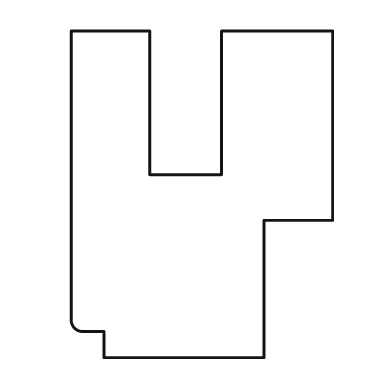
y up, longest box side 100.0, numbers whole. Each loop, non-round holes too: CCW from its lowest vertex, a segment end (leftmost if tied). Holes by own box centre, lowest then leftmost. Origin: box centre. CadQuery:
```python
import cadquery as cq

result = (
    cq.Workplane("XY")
    .moveTo(-30.0, -50.0)
    .lineTo(19.0, -50.0)
    .lineTo(19.0, -8.0)
    .lineTo(40.0, -8.0)
    .lineTo(40.0, 50.0)
    .lineTo(6.0, 50.0)
    .lineTo(6.0, 6.0)
    .lineTo(-16.0, 6.0)
    .lineTo(-16.0, 50.0)
    .lineTo(-40.0, 50.0)
    .lineTo(-40.0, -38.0)
    .threePointArc((-39.0, -41.0), (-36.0, -42.0))
    .lineTo(-30.0, -42.0)
    .close()
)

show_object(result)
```